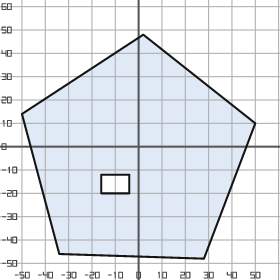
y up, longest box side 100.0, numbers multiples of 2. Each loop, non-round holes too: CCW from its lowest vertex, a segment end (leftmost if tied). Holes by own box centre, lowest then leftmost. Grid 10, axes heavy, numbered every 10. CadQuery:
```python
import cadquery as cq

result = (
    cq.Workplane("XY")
    .moveTo(28.0, -48.0)
    .lineTo(50.0, 10.0)
    .lineTo(2.0, 48.0)
    .lineTo(-50.0, 14.0)
    .lineTo(-34.0, -46.0)
    .close()
    .moveTo(-16.0, -20.0)
    .lineTo(-4.0, -20.0)
    .lineTo(-4.0, -12.0)
    .lineTo(-16.0, -12.0)
    .close()
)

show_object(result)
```